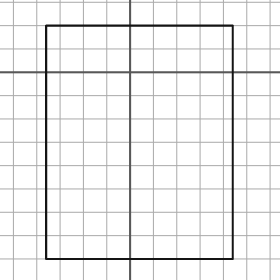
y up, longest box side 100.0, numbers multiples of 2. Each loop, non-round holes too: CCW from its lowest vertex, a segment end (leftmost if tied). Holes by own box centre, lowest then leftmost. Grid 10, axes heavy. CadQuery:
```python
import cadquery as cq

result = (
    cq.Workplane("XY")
    .moveTo(-36.0, -80.0)
    .lineTo(44.0, -80.0)
    .lineTo(44.0, 20.0)
    .lineTo(-36.0, 20.0)
    .close()
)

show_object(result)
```